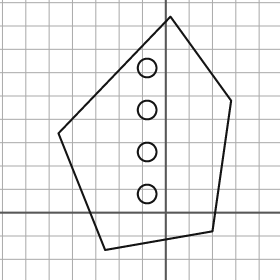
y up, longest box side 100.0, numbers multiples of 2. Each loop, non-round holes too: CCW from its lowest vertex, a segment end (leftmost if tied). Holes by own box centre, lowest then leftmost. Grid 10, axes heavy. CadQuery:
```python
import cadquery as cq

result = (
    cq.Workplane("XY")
    .moveTo(-26.0, -16.0)
    .lineTo(20.0, -8.0)
    .lineTo(28.0, 48.0)
    .lineTo(2.0, 84.0)
    .lineTo(-46.0, 34.0)
    .close()
    .moveTo(-8.0, 8.0)
    .circle(4.0)
    .moveTo(-8.0, 26.0)
    .circle(4.0)
    .moveTo(-8.0, 44.0)
    .circle(4.0)
    .moveTo(-8.0, 62.0)
    .circle(4.0)
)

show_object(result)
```